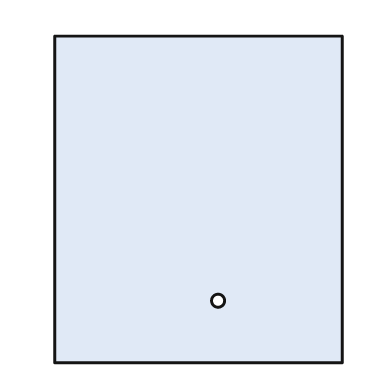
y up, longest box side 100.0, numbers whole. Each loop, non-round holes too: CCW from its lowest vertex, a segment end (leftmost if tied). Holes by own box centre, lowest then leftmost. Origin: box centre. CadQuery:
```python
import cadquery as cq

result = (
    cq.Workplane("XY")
    .moveTo(-44.0, -50.0)
    .lineTo(44.0, -50.0)
    .lineTo(44.0, 50.0)
    .lineTo(-44.0, 50.0)
    .close()
    .moveTo(6.0, -31.0)
    .circle(2.0)
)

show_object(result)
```